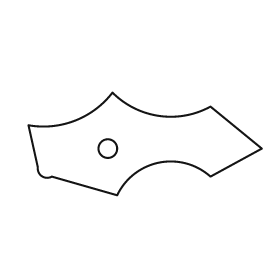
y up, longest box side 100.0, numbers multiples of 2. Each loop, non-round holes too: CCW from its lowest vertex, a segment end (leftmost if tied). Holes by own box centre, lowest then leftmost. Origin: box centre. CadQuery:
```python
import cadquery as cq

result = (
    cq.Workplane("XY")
    .moveTo(-12.0, -22.0)
    .threePointArc((6.0, -8.0), (28.0, -14.0))
    .lineTo(50.0, -2.0)
    .lineTo(28.0, 16.0)
    .threePointArc((6.0, 12.0), (-14.0, 22.0))
    .threePointArc((-30.0, 10.0), (-50.0, 8.0))
    .lineTo(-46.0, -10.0)
    .threePointArc((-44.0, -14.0), (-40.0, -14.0))
    .close()
    .moveTo(-16.0, -2.0)
    .circle(4.0)
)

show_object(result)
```